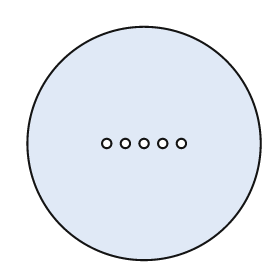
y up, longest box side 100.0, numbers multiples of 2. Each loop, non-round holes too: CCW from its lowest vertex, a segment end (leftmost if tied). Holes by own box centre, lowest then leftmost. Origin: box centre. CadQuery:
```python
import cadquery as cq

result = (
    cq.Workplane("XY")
    .moveTo(0.0, 0.0)
    .circle(50.0)
    .moveTo(-16.0, 0.0)
    .circle(2.0)
    .moveTo(-8.0, 0.0)
    .circle(2.0)
    .moveTo(0.0, 0.0)
    .circle(2.0)
    .moveTo(8.0, 0.0)
    .circle(2.0)
    .moveTo(16.0, 0.0)
    .circle(2.0)
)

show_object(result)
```